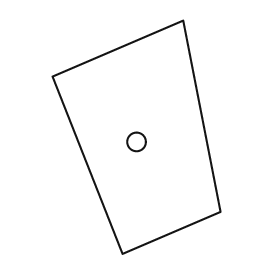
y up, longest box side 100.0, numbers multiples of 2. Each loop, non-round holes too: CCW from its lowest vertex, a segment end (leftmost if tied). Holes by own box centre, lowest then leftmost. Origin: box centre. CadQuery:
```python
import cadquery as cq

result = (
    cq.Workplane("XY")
    .moveTo(-6.0, -50.0)
    .lineTo(36.0, -32.0)
    .lineTo(20.0, 50.0)
    .lineTo(-36.0, 26.0)
    .close()
    .moveTo(0.0, -2.0)
    .circle(4.0)
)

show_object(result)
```